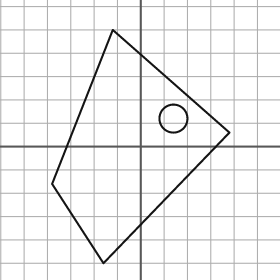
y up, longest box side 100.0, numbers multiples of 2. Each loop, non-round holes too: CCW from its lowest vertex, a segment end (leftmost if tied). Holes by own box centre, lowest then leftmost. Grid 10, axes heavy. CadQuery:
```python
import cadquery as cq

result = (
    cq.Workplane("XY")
    .moveTo(-16.0, -50.0)
    .lineTo(38.0, 6.0)
    .lineTo(-12.0, 50.0)
    .lineTo(-38.0, -16.0)
    .close()
    .moveTo(14.0, 12.0)
    .circle(6.0)
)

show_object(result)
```